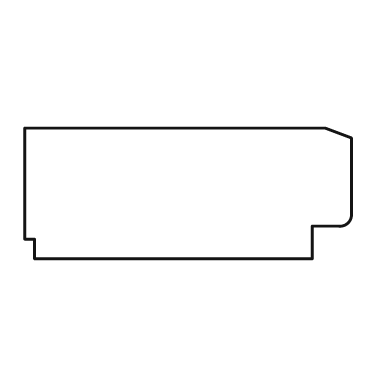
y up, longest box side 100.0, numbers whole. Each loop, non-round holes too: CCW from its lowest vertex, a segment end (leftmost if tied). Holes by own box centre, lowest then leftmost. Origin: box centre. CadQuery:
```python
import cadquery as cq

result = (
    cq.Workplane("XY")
    .moveTo(-47.0, -20.0)
    .lineTo(38.0, -20.0)
    .lineTo(38.0, -10.0)
    .lineTo(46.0, -10.0)
    .threePointArc((49.0, -9.0), (50.0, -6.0))
    .lineTo(50.0, 17.0)
    .lineTo(42.0, 20.0)
    .lineTo(-50.0, 20.0)
    .lineTo(-50.0, -14.0)
    .lineTo(-47.0, -14.0)
    .close()
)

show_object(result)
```